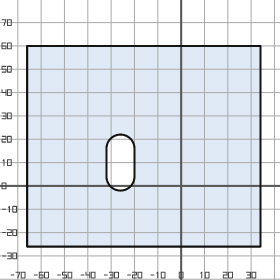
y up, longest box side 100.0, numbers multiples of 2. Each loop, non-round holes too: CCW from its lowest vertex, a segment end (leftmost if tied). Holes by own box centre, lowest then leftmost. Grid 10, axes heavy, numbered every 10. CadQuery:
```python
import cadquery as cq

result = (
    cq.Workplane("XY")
    .moveTo(-66.0, -26.0)
    .lineTo(34.0, -26.0)
    .lineTo(34.0, 60.0)
    .lineTo(-66.0, 60.0)
    .close()
    .moveTo(-32.0, 4.0)
    .threePointArc((-26.0, -2.0), (-20.0, 4.0))
    .lineTo(-20.0, 16.0)
    .threePointArc((-26.0, 22.0), (-32.0, 16.0))
    .close()
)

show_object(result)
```